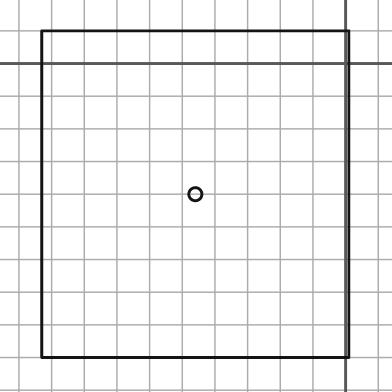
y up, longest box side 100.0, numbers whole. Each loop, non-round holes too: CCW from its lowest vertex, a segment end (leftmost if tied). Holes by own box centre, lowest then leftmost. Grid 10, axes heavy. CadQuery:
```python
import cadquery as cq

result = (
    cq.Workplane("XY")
    .moveTo(-93.0, -90.0)
    .lineTo(1.0, -90.0)
    .lineTo(1.0, 10.0)
    .lineTo(-93.0, 10.0)
    .close()
    .moveTo(-46.0, -40.0)
    .circle(2.0)
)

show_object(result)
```